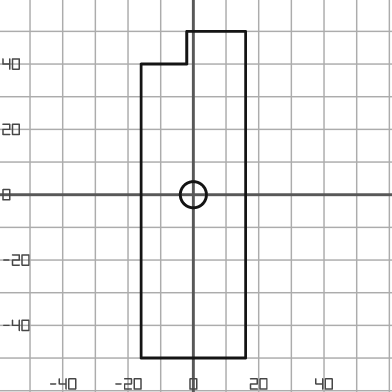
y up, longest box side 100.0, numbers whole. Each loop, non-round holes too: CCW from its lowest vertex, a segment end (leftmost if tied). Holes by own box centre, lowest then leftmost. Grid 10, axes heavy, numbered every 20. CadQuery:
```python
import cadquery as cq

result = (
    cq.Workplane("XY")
    .moveTo(-16.0, -50.0)
    .lineTo(16.0, -50.0)
    .lineTo(16.0, 50.0)
    .lineTo(-2.0, 50.0)
    .lineTo(-2.0, 40.0)
    .lineTo(-16.0, 40.0)
    .close()
    .moveTo(0.0, 0.0)
    .circle(4.0)
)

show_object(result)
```